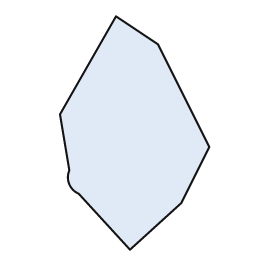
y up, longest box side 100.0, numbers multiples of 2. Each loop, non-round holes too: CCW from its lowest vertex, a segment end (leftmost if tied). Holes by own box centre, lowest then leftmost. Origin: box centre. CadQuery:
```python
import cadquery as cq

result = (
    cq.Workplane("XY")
    .moveTo(-2.0, -50.0)
    .lineTo(20.0, -30.0)
    .lineTo(32.0, -6.0)
    .lineTo(10.0, 38.0)
    .lineTo(-8.0, 50.0)
    .lineTo(-32.0, 8.0)
    .lineTo(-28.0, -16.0)
    .threePointArc((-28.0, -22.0), (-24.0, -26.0))
    .close()
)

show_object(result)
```